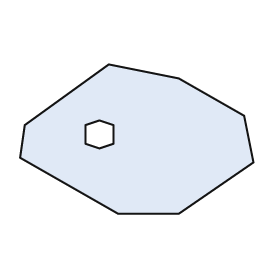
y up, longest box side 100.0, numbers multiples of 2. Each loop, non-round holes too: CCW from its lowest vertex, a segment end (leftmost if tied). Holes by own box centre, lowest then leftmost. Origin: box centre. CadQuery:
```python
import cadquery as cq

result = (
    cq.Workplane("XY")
    .moveTo(-8.0, -32.0)
    .lineTo(18.0, -32.0)
    .lineTo(50.0, -10.0)
    .lineTo(46.0, 10.0)
    .lineTo(18.0, 26.0)
    .lineTo(-12.0, 32.0)
    .lineTo(-48.0, 6.0)
    .lineTo(-50.0, -8.0)
    .close()
    .moveTo(-16.0, -4.0)
    .lineTo(-10.0, -2.0)
    .lineTo(-10.0, 6.0)
    .lineTo(-16.0, 8.0)
    .lineTo(-22.0, 6.0)
    .lineTo(-22.0, -2.0)
    .close()
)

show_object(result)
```